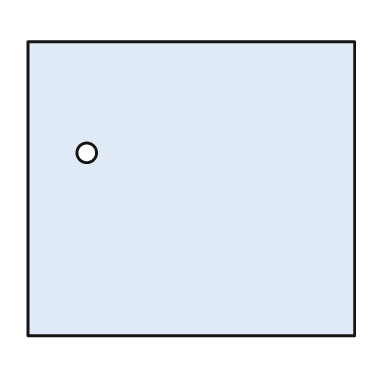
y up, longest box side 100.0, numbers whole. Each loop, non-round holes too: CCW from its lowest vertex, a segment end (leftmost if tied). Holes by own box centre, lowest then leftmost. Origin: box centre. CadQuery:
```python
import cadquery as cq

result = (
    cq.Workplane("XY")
    .moveTo(-50.0, -45.0)
    .lineTo(50.0, -45.0)
    .lineTo(50.0, 45.0)
    .lineTo(-50.0, 45.0)
    .close()
    .moveTo(-32.0, 11.0)
    .circle(3.0)
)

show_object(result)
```